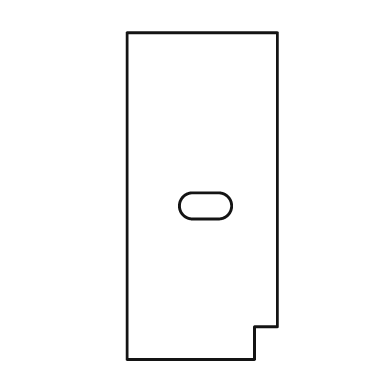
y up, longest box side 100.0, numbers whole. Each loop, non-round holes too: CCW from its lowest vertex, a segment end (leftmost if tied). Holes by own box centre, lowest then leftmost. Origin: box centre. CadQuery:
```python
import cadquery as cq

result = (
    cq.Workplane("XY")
    .moveTo(-23.0, -50.0)
    .lineTo(16.0, -50.0)
    .lineTo(16.0, -40.0)
    .lineTo(23.0, -40.0)
    .lineTo(23.0, 50.0)
    .lineTo(-23.0, 50.0)
    .close()
    .moveTo(-3.0, -7.0)
    .lineTo(5.0, -7.0)
    .threePointArc((9.0, -3.0), (5.0, 1.0))
    .lineTo(-3.0, 1.0)
    .threePointArc((-7.0, -3.0), (-3.0, -7.0))
    .close()
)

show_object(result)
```